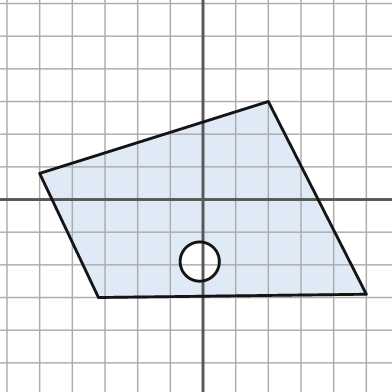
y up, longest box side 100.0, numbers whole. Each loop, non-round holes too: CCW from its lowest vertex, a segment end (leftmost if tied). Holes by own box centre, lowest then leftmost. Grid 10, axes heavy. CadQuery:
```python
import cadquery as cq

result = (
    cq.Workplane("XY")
    .moveTo(-32.0, -30.0)
    .lineTo(50.0, -29.0)
    .lineTo(20.0, 30.0)
    .lineTo(-50.0, 8.0)
    .close()
    .moveTo(-1.0, -19.0)
    .circle(6.0)
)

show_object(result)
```